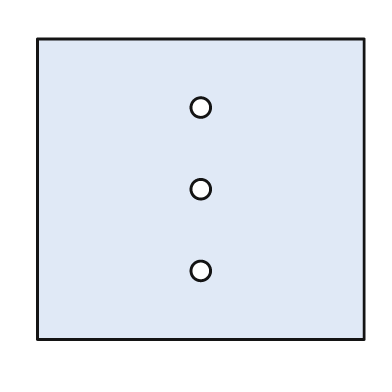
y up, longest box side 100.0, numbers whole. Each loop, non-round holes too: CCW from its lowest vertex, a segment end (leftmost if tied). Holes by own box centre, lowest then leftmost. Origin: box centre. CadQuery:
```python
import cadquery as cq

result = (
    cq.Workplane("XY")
    .moveTo(-50.0, -46.0)
    .lineTo(50.0, -46.0)
    .lineTo(50.0, 46.0)
    .lineTo(-50.0, 46.0)
    .close()
    .moveTo(0.0, -25.0)
    .circle(3.0)
    .moveTo(0.0, 0.0)
    .circle(3.0)
    .moveTo(0.0, 25.0)
    .circle(3.0)
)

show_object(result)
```